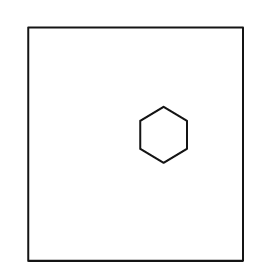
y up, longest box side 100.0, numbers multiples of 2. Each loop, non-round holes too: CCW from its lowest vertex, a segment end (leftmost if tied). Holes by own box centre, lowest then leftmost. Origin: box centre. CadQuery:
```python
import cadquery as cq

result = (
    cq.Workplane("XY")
    .moveTo(-46.0, -50.0)
    .lineTo(46.0, -50.0)
    .lineTo(46.0, 50.0)
    .lineTo(-46.0, 50.0)
    .close()
    .moveTo(12.0, -8.0)
    .lineTo(22.0, -2.0)
    .lineTo(22.0, 10.0)
    .lineTo(12.0, 16.0)
    .lineTo(2.0, 10.0)
    .lineTo(2.0, -2.0)
    .close()
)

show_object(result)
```